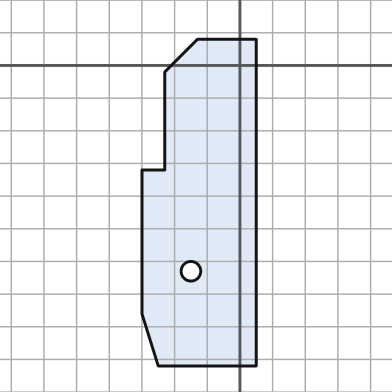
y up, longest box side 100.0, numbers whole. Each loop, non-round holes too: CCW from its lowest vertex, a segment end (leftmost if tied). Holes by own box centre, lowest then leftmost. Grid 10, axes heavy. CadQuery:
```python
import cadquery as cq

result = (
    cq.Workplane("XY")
    .moveTo(-25.0, -92.0)
    .lineTo(5.0, -92.0)
    .lineTo(5.0, 8.0)
    .lineTo(-13.0, 8.0)
    .lineTo(-23.0, -2.0)
    .lineTo(-23.0, -32.0)
    .lineTo(-30.0, -32.0)
    .lineTo(-30.0, -76.0)
    .close()
    .moveTo(-15.0, -63.0)
    .circle(3.0)
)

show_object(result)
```